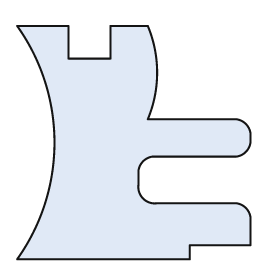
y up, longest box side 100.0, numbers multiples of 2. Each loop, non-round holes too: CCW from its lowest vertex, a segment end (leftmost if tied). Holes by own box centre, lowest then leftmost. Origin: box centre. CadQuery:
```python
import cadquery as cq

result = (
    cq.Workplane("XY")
    .moveTo(-50.0, -50.0)
    .lineTo(24.0, -50.0)
    .lineTo(24.0, -44.0)
    .lineTo(50.0, -44.0)
    .lineTo(50.0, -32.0)
    .threePointArc((48.0, -28.0), (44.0, -26.0))
    .lineTo(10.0, -26.0)
    .threePointArc((4.0, -24.0), (2.0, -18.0))
    .lineTo(2.0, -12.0)
    .threePointArc((4.0, -8.0), (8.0, -6.0))
    .lineTo(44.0, -6.0)
    .threePointArc((48.0, -4.0), (50.0, 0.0))
    .lineTo(50.0, 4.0)
    .threePointArc((48.0, 8.0), (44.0, 10.0))
    .lineTo(6.0, 10.0)
    .threePointArc((10.0, 30.0), (6.0, 50.0))
    .lineTo(-10.0, 50.0)
    .lineTo(-10.0, 36.0)
    .lineTo(-28.0, 36.0)
    .lineTo(-28.0, 50.0)
    .lineTo(-50.0, 50.0)
    .threePointArc((-34.0, 0.0), (-50.0, -50.0))
    .close()
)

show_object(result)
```